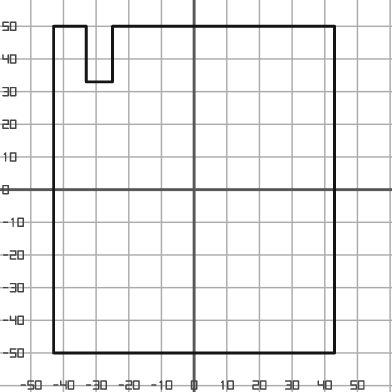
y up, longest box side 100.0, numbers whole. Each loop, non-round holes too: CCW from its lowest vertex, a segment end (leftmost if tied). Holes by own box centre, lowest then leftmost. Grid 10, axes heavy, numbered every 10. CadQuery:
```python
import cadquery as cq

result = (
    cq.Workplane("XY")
    .moveTo(-43.0, -50.0)
    .lineTo(43.0, -50.0)
    .lineTo(43.0, 50.0)
    .lineTo(-25.0, 50.0)
    .lineTo(-25.0, 33.0)
    .lineTo(-33.0, 33.0)
    .lineTo(-33.0, 50.0)
    .lineTo(-43.0, 50.0)
    .close()
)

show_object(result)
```